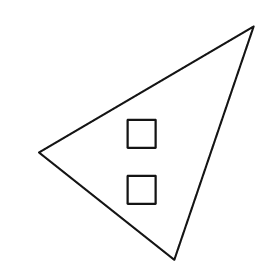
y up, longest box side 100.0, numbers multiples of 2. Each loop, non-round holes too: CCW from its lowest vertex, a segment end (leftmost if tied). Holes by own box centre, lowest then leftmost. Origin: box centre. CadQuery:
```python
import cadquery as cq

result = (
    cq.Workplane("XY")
    .moveTo(12.0, -50.0)
    .lineTo(46.0, 50.0)
    .lineTo(-46.0, -4.0)
    .close()
    .moveTo(-8.0, -26.0)
    .lineTo(4.0, -26.0)
    .lineTo(4.0, -14.0)
    .lineTo(-8.0, -14.0)
    .close()
    .moveTo(-8.0, -2.0)
    .lineTo(4.0, -2.0)
    .lineTo(4.0, 10.0)
    .lineTo(-8.0, 10.0)
    .close()
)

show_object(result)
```